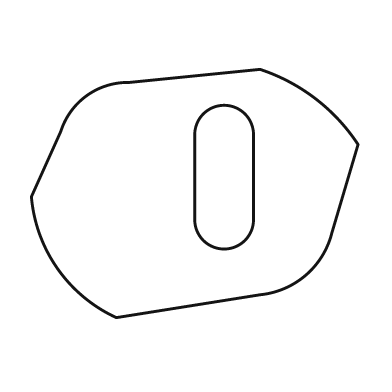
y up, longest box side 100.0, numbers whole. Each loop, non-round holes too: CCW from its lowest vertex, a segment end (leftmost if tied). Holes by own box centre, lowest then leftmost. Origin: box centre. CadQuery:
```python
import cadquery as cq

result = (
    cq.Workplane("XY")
    .moveTo(-24.0, -38.0)
    .lineTo(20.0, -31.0)
    .threePointArc((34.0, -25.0), (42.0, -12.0))
    .lineTo(50.0, 15.0)
    .threePointArc((37.0, 29.0), (20.0, 38.0))
    .lineTo(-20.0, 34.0)
    .threePointArc((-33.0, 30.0), (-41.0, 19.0))
    .lineTo(-50.0, -1.0)
    .threePointArc((-42.0, -23.0), (-24.0, -38.0))
    .close()
    .moveTo(0.0, -8.0)
    .threePointArc((9.0, -17.0), (18.0, -8.0))
    .lineTo(18.0, 18.0)
    .threePointArc((9.0, 27.0), (0.0, 18.0))
    .close()
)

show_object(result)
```